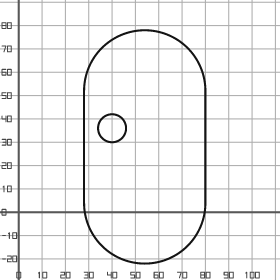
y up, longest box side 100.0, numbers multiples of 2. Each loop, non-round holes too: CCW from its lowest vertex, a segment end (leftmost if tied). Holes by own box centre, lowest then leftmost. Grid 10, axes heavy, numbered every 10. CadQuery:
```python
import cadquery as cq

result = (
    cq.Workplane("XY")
    .moveTo(28.0, 4.0)
    .threePointArc((54.0, -22.0), (80.0, 4.0))
    .lineTo(80.0, 52.0)
    .threePointArc((54.0, 78.0), (28.0, 52.0))
    .close()
    .moveTo(40.0, 36.0)
    .circle(6.0)
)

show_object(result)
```